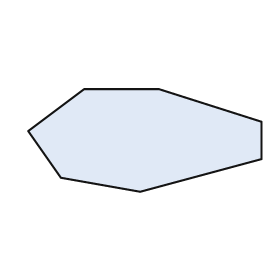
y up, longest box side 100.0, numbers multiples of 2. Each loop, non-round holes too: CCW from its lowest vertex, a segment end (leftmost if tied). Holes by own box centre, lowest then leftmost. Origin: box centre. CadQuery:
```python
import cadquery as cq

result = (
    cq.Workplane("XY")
    .moveTo(-2.0, -22.0)
    .lineTo(50.0, -8.0)
    .lineTo(50.0, 8.0)
    .lineTo(6.0, 22.0)
    .lineTo(-26.0, 22.0)
    .lineTo(-50.0, 4.0)
    .lineTo(-36.0, -16.0)
    .close()
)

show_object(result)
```